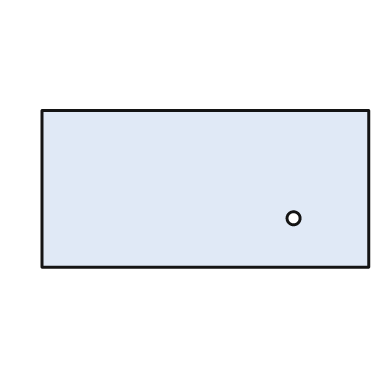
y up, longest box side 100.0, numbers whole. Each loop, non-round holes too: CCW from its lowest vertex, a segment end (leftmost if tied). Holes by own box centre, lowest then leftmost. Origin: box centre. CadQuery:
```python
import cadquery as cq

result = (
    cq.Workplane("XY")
    .moveTo(-50.0, -24.0)
    .lineTo(50.0, -24.0)
    .lineTo(50.0, 24.0)
    .lineTo(-50.0, 24.0)
    .close()
    .moveTo(27.0, -9.0)
    .circle(2.0)
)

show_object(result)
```